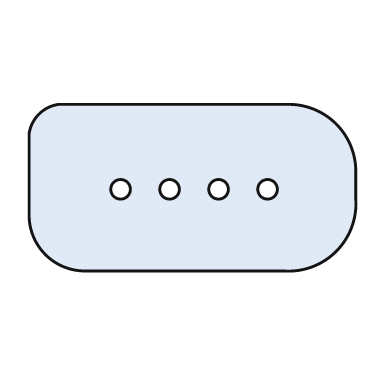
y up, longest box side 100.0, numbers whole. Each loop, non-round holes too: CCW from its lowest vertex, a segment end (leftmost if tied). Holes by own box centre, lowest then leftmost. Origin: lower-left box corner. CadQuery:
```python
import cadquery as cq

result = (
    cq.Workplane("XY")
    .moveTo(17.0, 0.0)
    .lineTo(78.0, 0.0)
    .threePointArc((94.0, 6.0), (100.0, 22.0))
    .lineTo(100.0, 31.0)
    .threePointArc((94.0, 45.0), (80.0, 51.0))
    .lineTo(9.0, 51.0)
    .threePointArc((3.0, 48.0), (0.0, 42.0))
    .lineTo(0.0, 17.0)
    .threePointArc((5.0, 5.0), (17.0, 0.0))
    .close()
    .moveTo(28.0, 25.0)
    .circle(3.0)
    .moveTo(43.0, 25.0)
    .circle(3.0)
    .moveTo(58.0, 25.0)
    .circle(3.0)
    .moveTo(73.0, 25.0)
    .circle(3.0)
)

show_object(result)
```